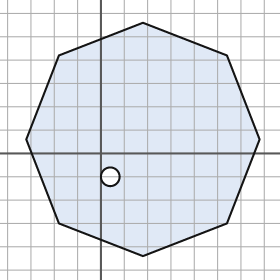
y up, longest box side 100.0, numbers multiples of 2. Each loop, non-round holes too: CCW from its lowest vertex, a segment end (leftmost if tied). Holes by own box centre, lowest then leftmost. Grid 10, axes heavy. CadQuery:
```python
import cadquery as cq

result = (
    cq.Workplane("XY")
    .moveTo(18.0, -44.0)
    .lineTo(54.0, -30.0)
    .lineTo(68.0, 6.0)
    .lineTo(54.0, 42.0)
    .lineTo(18.0, 56.0)
    .lineTo(-18.0, 42.0)
    .lineTo(-32.0, 6.0)
    .lineTo(-18.0, -30.0)
    .close()
    .moveTo(4.0, -10.0)
    .circle(4.0)
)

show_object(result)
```